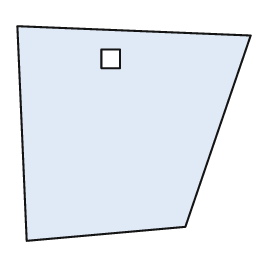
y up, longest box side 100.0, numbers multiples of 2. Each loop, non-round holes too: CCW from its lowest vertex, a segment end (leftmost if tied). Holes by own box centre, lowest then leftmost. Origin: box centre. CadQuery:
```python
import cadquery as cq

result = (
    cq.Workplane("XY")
    .moveTo(-46.0, -46.0)
    .lineTo(22.0, -40.0)
    .lineTo(50.0, 42.0)
    .lineTo(-50.0, 46.0)
    .close()
    .moveTo(-14.0, 28.0)
    .lineTo(-6.0, 28.0)
    .lineTo(-6.0, 36.0)
    .lineTo(-14.0, 36.0)
    .close()
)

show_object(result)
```